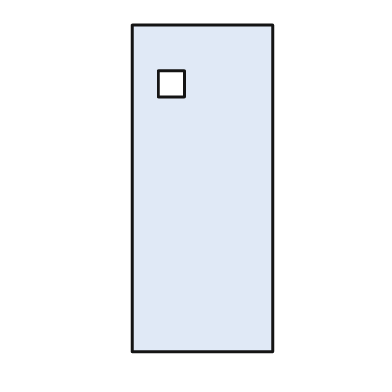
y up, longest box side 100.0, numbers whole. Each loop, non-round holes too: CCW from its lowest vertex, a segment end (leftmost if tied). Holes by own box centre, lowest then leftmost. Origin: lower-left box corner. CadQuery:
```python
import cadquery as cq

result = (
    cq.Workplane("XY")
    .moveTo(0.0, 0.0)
    .lineTo(43.0, 0.0)
    .lineTo(43.0, 100.0)
    .lineTo(0.0, 100.0)
    .close()
    .moveTo(8.0, 78.0)
    .lineTo(16.0, 78.0)
    .lineTo(16.0, 86.0)
    .lineTo(8.0, 86.0)
    .close()
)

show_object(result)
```